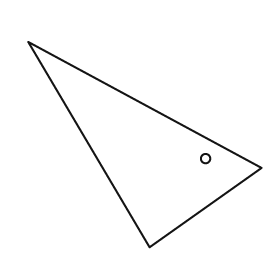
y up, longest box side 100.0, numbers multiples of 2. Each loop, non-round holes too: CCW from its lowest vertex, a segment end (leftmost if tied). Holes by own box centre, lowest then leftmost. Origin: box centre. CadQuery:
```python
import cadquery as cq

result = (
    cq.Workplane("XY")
    .moveTo(2.0, -44.0)
    .lineTo(50.0, -10.0)
    .lineTo(-50.0, 44.0)
    .close()
    .moveTo(26.0, -6.0)
    .circle(2.0)
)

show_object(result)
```